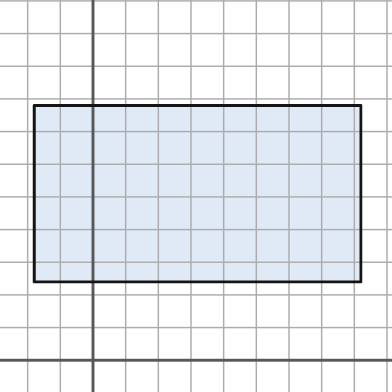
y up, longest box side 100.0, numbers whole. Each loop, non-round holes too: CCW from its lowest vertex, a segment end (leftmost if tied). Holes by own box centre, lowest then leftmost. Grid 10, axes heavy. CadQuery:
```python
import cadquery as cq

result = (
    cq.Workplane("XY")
    .moveTo(-18.0, 24.0)
    .lineTo(82.0, 24.0)
    .lineTo(82.0, 78.0)
    .lineTo(-18.0, 78.0)
    .close()
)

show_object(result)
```